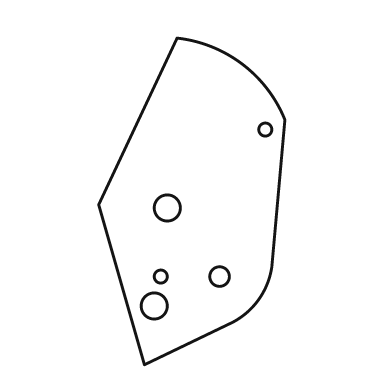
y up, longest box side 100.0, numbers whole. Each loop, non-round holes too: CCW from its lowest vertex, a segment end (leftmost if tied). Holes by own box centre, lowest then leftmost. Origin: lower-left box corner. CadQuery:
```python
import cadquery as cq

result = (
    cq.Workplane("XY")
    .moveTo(14.0, 0.0)
    .lineTo(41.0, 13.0)
    .threePointArc((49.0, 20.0), (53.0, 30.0))
    .lineTo(57.0, 75.0)
    .threePointArc((44.0, 92.0), (24.0, 100.0))
    .lineTo(0.0, 49.0)
    .close()
    .moveTo(17.0, 18.0)
    .circle(4.0)
    .moveTo(19.0, 27.0)
    .circle(2.0)
    .moveTo(37.0, 27.0)
    .circle(3.0)
    .moveTo(21.0, 48.0)
    .circle(4.0)
    .moveTo(51.0, 72.0)
    .circle(2.0)
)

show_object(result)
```